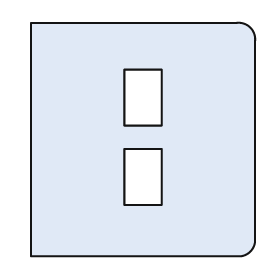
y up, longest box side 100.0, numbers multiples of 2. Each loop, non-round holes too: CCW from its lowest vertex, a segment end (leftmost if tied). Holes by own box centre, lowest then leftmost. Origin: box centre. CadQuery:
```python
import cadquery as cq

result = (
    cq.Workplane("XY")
    .moveTo(-48.0, -50.0)
    .lineTo(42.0, -50.0)
    .threePointArc((46.0, -48.0), (48.0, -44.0))
    .lineTo(48.0, 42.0)
    .threePointArc((46.0, 48.0), (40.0, 50.0))
    .lineTo(-48.0, 50.0)
    .close()
    .moveTo(-8.0, -28.0)
    .lineTo(8.0, -28.0)
    .lineTo(8.0, -4.0)
    .lineTo(-8.0, -4.0)
    .close()
    .moveTo(-8.0, 6.0)
    .lineTo(8.0, 6.0)
    .lineTo(8.0, 30.0)
    .lineTo(-8.0, 30.0)
    .close()
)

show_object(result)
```